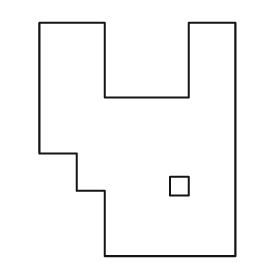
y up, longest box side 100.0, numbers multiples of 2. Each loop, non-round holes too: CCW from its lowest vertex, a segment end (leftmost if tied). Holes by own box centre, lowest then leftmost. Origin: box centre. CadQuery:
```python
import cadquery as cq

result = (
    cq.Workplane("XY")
    .moveTo(-14.0, -50.0)
    .lineTo(42.0, -50.0)
    .lineTo(42.0, 50.0)
    .lineTo(22.0, 50.0)
    .lineTo(22.0, 18.0)
    .lineTo(-14.0, 18.0)
    .lineTo(-14.0, 50.0)
    .lineTo(-42.0, 50.0)
    .lineTo(-42.0, -6.0)
    .lineTo(-26.0, -6.0)
    .lineTo(-26.0, -22.0)
    .lineTo(-14.0, -22.0)
    .close()
    .moveTo(14.0, -24.0)
    .lineTo(22.0, -24.0)
    .lineTo(22.0, -16.0)
    .lineTo(14.0, -16.0)
    .close()
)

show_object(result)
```